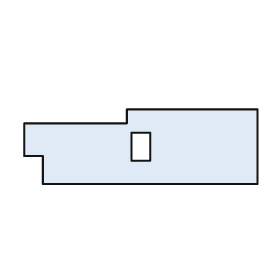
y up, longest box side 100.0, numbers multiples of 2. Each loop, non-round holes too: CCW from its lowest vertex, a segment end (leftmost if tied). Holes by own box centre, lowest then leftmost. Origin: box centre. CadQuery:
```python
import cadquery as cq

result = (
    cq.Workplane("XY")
    .moveTo(-42.0, -16.0)
    .lineTo(50.0, -16.0)
    .lineTo(50.0, 16.0)
    .lineTo(-6.0, 16.0)
    .lineTo(-6.0, 10.0)
    .lineTo(-50.0, 10.0)
    .lineTo(-50.0, -4.0)
    .lineTo(-42.0, -4.0)
    .close()
    .moveTo(-4.0, -6.0)
    .lineTo(4.0, -6.0)
    .lineTo(4.0, 6.0)
    .lineTo(-4.0, 6.0)
    .close()
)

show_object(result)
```